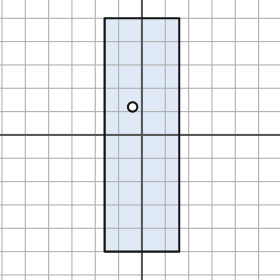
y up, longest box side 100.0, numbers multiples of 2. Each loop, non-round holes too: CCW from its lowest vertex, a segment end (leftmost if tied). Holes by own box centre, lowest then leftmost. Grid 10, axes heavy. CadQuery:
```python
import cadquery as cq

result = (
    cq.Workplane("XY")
    .moveTo(-16.0, -50.0)
    .lineTo(16.0, -50.0)
    .lineTo(16.0, 50.0)
    .lineTo(-16.0, 50.0)
    .close()
    .moveTo(-4.0, 12.0)
    .circle(2.0)
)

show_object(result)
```